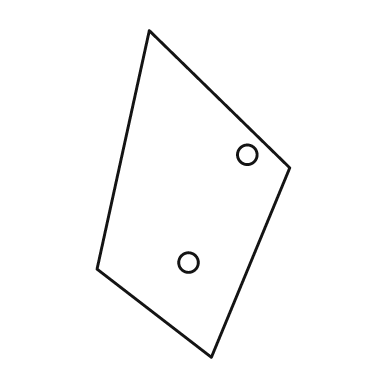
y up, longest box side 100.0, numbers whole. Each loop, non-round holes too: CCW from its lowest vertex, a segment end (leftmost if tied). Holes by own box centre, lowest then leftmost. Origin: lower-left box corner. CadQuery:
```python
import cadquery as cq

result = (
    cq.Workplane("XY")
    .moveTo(35.0, 0.0)
    .lineTo(59.0, 58.0)
    .lineTo(16.0, 100.0)
    .lineTo(0.0, 27.0)
    .close()
    .moveTo(28.0, 29.0)
    .circle(3.0)
    .moveTo(46.0, 62.0)
    .circle(3.0)
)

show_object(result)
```